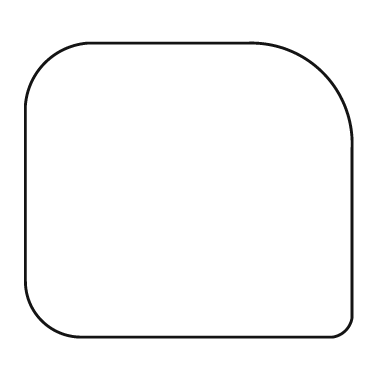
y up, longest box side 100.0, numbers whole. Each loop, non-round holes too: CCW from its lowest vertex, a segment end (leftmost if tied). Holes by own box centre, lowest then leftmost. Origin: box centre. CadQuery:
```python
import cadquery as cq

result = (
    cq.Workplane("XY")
    .moveTo(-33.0, -45.0)
    .lineTo(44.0, -45.0)
    .threePointArc((48.0, -43.0), (50.0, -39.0))
    .lineTo(50.0, 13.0)
    .threePointArc((41.0, 36.0), (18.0, 45.0))
    .lineTo(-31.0, 45.0)
    .threePointArc((-44.0, 39.0), (-50.0, 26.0))
    .lineTo(-50.0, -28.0)
    .threePointArc((-45.0, -40.0), (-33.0, -45.0))
    .close()
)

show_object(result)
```